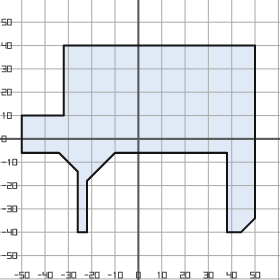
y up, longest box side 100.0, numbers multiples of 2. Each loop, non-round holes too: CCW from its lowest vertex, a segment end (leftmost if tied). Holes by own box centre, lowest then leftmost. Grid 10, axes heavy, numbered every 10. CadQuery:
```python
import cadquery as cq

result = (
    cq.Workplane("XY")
    .moveTo(-26.0, -40.0)
    .lineTo(-22.0, -40.0)
    .lineTo(-22.0, -18.0)
    .lineTo(-10.0, -6.0)
    .lineTo(38.0, -6.0)
    .lineTo(38.0, -40.0)
    .lineTo(44.0, -40.0)
    .lineTo(50.0, -34.0)
    .lineTo(50.0, 40.0)
    .lineTo(-32.0, 40.0)
    .lineTo(-32.0, 10.0)
    .lineTo(-50.0, 10.0)
    .lineTo(-50.0, -6.0)
    .lineTo(-34.0, -6.0)
    .lineTo(-26.0, -14.0)
    .close()
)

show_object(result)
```